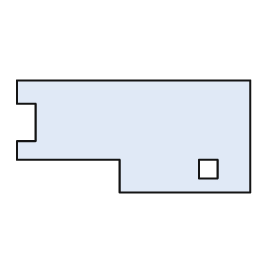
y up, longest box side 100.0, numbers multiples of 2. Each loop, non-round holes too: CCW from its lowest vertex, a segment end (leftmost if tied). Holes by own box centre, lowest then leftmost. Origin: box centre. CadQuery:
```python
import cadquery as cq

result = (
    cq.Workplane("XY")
    .moveTo(-6.0, -24.0)
    .lineTo(50.0, -24.0)
    .lineTo(50.0, 24.0)
    .lineTo(-50.0, 24.0)
    .lineTo(-50.0, 14.0)
    .lineTo(-42.0, 14.0)
    .lineTo(-42.0, -2.0)
    .lineTo(-50.0, -2.0)
    .lineTo(-50.0, -10.0)
    .lineTo(-6.0, -10.0)
    .close()
    .moveTo(28.0, -18.0)
    .lineTo(36.0, -18.0)
    .lineTo(36.0, -10.0)
    .lineTo(28.0, -10.0)
    .close()
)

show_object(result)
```